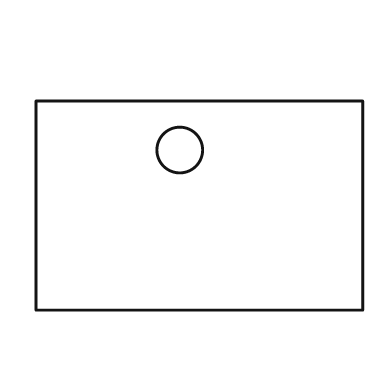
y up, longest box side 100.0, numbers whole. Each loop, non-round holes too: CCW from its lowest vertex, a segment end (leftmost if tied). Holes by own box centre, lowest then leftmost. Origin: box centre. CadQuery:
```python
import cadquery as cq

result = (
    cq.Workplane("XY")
    .moveTo(-50.0, -32.0)
    .lineTo(50.0, -32.0)
    .lineTo(50.0, 32.0)
    .lineTo(-50.0, 32.0)
    .close()
    .moveTo(-6.0, 17.0)
    .circle(7.0)
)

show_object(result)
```